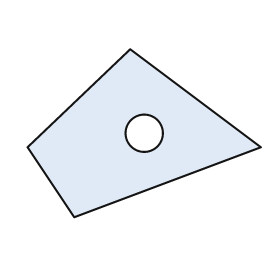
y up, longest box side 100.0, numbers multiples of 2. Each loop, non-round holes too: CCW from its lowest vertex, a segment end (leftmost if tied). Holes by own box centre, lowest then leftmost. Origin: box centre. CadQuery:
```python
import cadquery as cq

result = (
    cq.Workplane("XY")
    .moveTo(-30.0, -36.0)
    .lineTo(50.0, -6.0)
    .lineTo(-6.0, 36.0)
    .lineTo(-50.0, -6.0)
    .close()
    .moveTo(0.0, 0.0)
    .circle(8.0)
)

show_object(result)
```